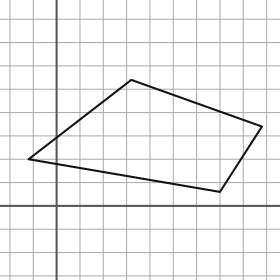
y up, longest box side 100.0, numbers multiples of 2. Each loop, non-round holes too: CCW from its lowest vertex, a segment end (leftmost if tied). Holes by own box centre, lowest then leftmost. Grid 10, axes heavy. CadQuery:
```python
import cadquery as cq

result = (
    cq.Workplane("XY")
    .moveTo(70.0, 6.0)
    .lineTo(88.0, 34.0)
    .lineTo(32.0, 54.0)
    .lineTo(-12.0, 20.0)
    .close()
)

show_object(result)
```